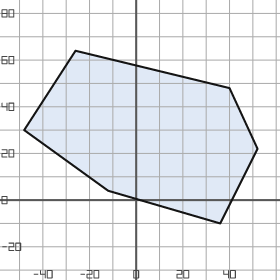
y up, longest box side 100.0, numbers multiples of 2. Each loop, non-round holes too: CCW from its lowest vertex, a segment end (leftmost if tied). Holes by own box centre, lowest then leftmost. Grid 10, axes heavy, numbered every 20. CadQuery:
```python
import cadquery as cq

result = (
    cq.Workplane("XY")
    .moveTo(36.0, -10.0)
    .lineTo(52.0, 22.0)
    .lineTo(40.0, 48.0)
    .lineTo(-26.0, 64.0)
    .lineTo(-48.0, 30.0)
    .lineTo(-12.0, 4.0)
    .close()
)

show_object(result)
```